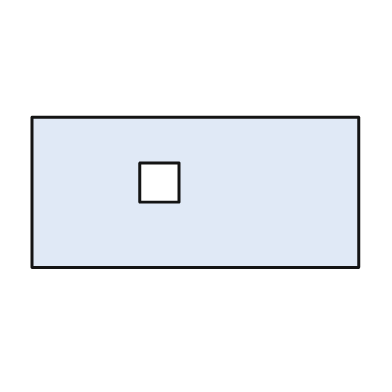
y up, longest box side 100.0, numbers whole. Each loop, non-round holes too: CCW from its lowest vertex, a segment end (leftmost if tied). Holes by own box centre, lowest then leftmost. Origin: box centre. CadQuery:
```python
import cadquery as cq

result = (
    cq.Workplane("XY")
    .moveTo(-50.0, -23.0)
    .lineTo(50.0, -23.0)
    .lineTo(50.0, 23.0)
    .lineTo(-50.0, 23.0)
    .close()
    .moveTo(-17.0, -3.0)
    .lineTo(-5.0, -3.0)
    .lineTo(-5.0, 9.0)
    .lineTo(-17.0, 9.0)
    .close()
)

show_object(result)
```